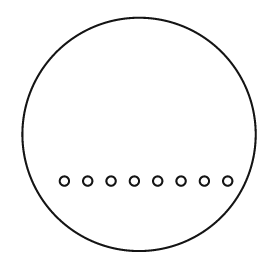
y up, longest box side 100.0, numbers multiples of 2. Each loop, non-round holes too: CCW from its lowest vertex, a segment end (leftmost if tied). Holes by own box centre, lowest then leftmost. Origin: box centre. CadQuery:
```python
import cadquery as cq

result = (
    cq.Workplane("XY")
    .moveTo(0.0, 0.0)
    .circle(50.0)
    .moveTo(-32.0, -20.0)
    .circle(2.0)
    .moveTo(-22.0, -20.0)
    .circle(2.0)
    .moveTo(-12.0, -20.0)
    .circle(2.0)
    .moveTo(-2.0, -20.0)
    .circle(2.0)
    .moveTo(8.0, -20.0)
    .circle(2.0)
    .moveTo(18.0, -20.0)
    .circle(2.0)
    .moveTo(28.0, -20.0)
    .circle(2.0)
    .moveTo(38.0, -20.0)
    .circle(2.0)
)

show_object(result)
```